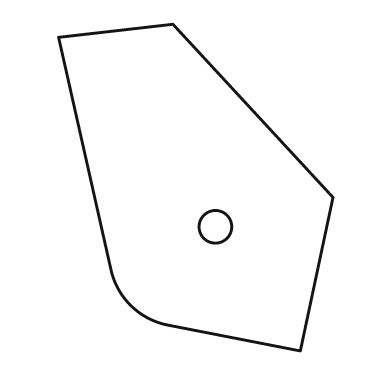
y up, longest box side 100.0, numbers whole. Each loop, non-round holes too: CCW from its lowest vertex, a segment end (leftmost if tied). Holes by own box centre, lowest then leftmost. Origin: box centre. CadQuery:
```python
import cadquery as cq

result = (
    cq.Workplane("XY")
    .moveTo(32.0, -50.0)
    .lineTo(42.0, -3.0)
    .lineTo(-7.0, 50.0)
    .lineTo(-42.0, 46.0)
    .lineTo(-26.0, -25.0)
    .threePointArc((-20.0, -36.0), (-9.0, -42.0))
    .close()
    .moveTo(6.0, -12.0)
    .circle(5.0)
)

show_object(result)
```